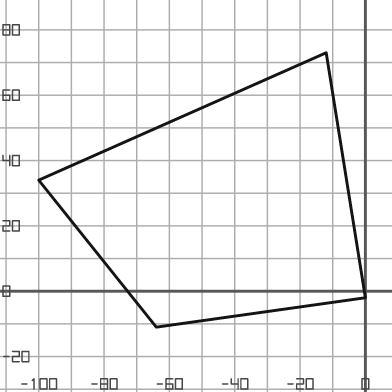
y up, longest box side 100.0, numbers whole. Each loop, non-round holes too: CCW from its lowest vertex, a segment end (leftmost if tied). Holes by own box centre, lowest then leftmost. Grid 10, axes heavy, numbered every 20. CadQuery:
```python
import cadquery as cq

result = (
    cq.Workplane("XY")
    .moveTo(-64.0, -11.0)
    .lineTo(0.0, -2.0)
    .lineTo(-12.0, 73.0)
    .lineTo(-100.0, 34.0)
    .close()
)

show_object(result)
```